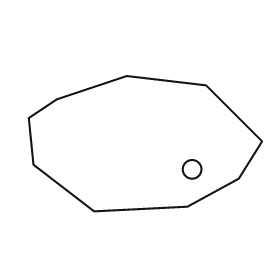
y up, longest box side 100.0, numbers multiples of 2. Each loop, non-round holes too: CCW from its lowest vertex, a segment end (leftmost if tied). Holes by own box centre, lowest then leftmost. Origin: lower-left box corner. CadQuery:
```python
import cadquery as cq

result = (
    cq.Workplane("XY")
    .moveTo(28.0, 0.0)
    .lineTo(68.0, 2.0)
    .lineTo(90.0, 14.0)
    .lineTo(100.0, 30.0)
    .lineTo(76.0, 54.0)
    .lineTo(42.0, 58.0)
    .lineTo(12.0, 48.0)
    .lineTo(0.0, 40.0)
    .lineTo(2.0, 20.0)
    .close()
    .moveTo(70.0, 18.0)
    .circle(4.0)
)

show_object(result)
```